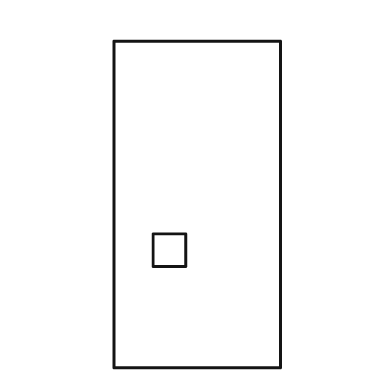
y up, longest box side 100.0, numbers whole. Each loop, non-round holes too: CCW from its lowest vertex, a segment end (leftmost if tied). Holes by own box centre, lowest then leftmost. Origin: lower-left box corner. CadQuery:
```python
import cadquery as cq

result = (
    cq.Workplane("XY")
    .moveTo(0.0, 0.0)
    .lineTo(51.0, 0.0)
    .lineTo(51.0, 100.0)
    .lineTo(0.0, 100.0)
    .close()
    .moveTo(12.0, 31.0)
    .lineTo(22.0, 31.0)
    .lineTo(22.0, 41.0)
    .lineTo(12.0, 41.0)
    .close()
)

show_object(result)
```